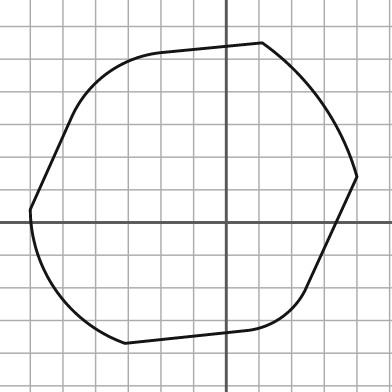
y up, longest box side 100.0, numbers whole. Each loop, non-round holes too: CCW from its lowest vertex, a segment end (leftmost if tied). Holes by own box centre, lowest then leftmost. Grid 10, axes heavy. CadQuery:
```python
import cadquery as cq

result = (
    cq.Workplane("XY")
    .moveTo(-31.0, -37.0)
    .lineTo(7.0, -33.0)
    .threePointArc((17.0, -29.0), (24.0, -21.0))
    .lineTo(40.0, 14.0)
    .threePointArc((29.0, 37.0), (11.0, 55.0))
    .lineTo(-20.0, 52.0)
    .threePointArc((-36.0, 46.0), (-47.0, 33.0))
    .lineTo(-60.0, 4.0)
    .threePointArc((-52.0, -21.0), (-31.0, -37.0))
    .close()
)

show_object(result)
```